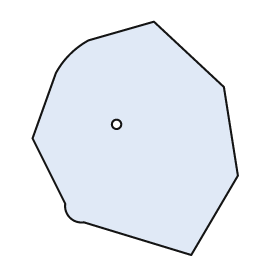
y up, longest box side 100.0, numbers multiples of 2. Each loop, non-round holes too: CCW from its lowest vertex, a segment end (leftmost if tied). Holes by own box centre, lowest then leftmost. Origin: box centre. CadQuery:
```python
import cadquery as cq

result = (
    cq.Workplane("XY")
    .moveTo(24.0, -50.0)
    .lineTo(44.0, -16.0)
    .lineTo(38.0, 22.0)
    .lineTo(8.0, 50.0)
    .lineTo(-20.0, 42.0)
    .threePointArc((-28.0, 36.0), (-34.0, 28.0))
    .lineTo(-44.0, 0.0)
    .lineTo(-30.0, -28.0)
    .threePointArc((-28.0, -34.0), (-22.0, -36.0))
    .close()
    .moveTo(-8.0, 6.0)
    .circle(2.0)
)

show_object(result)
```